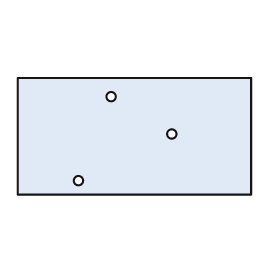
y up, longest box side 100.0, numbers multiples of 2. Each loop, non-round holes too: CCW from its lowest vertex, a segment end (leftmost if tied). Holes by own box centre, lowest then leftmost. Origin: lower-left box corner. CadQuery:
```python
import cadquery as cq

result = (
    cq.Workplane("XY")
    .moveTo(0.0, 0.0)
    .lineTo(100.0, 0.0)
    .lineTo(100.0, 50.0)
    .lineTo(0.0, 50.0)
    .close()
    .moveTo(26.0, 6.0)
    .circle(2.0)
    .moveTo(66.0, 26.0)
    .circle(2.0)
    .moveTo(40.0, 42.0)
    .circle(2.0)
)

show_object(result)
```